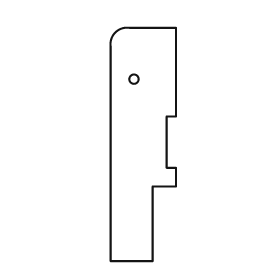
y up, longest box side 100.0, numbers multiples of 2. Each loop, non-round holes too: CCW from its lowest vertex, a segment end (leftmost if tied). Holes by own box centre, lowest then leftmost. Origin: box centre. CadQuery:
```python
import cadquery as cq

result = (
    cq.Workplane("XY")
    .moveTo(-14.0, -50.0)
    .lineTo(4.0, -50.0)
    .lineTo(4.0, -18.0)
    .lineTo(14.0, -18.0)
    .lineTo(14.0, -10.0)
    .lineTo(10.0, -10.0)
    .lineTo(10.0, 12.0)
    .lineTo(14.0, 12.0)
    .lineTo(14.0, 50.0)
    .lineTo(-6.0, 50.0)
    .threePointArc((-12.0, 48.0), (-14.0, 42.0))
    .close()
    .moveTo(-4.0, 28.0)
    .circle(2.0)
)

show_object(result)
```